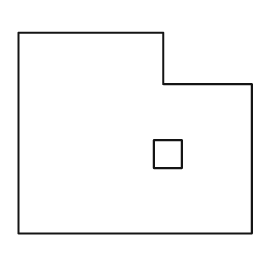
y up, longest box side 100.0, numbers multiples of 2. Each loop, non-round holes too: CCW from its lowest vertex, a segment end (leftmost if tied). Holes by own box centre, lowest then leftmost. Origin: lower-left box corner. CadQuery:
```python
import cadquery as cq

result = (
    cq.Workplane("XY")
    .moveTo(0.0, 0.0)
    .lineTo(100.0, 0.0)
    .lineTo(100.0, 64.0)
    .lineTo(62.0, 64.0)
    .lineTo(62.0, 86.0)
    .lineTo(0.0, 86.0)
    .close()
    .moveTo(58.0, 28.0)
    .lineTo(70.0, 28.0)
    .lineTo(70.0, 40.0)
    .lineTo(58.0, 40.0)
    .close()
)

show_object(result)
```